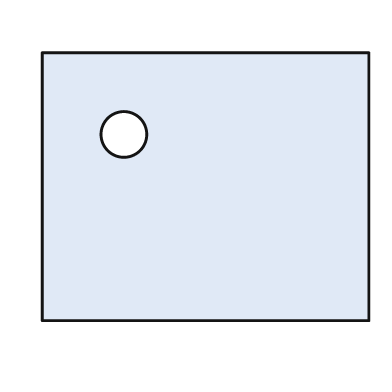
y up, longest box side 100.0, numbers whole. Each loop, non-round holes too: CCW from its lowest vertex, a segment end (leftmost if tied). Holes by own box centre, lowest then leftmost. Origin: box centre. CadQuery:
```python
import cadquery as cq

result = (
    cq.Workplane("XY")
    .moveTo(-50.0, -41.0)
    .lineTo(50.0, -41.0)
    .lineTo(50.0, 41.0)
    .lineTo(-50.0, 41.0)
    .close()
    .moveTo(-25.0, 16.0)
    .circle(7.0)
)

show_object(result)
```